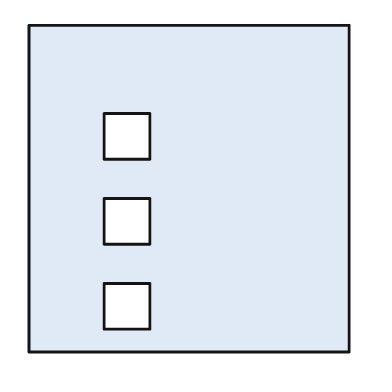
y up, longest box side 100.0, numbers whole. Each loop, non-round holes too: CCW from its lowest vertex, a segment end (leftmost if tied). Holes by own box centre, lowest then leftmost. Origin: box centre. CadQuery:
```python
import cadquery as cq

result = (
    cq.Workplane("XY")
    .moveTo(-49.0, -50.0)
    .lineTo(49.0, -50.0)
    .lineTo(49.0, 50.0)
    .lineTo(-49.0, 50.0)
    .close()
    .moveTo(-26.0, -43.0)
    .lineTo(-12.0, -43.0)
    .lineTo(-12.0, -29.0)
    .lineTo(-26.0, -29.0)
    .close()
    .moveTo(-26.0, -17.0)
    .lineTo(-12.0, -17.0)
    .lineTo(-12.0, -3.0)
    .lineTo(-26.0, -3.0)
    .close()
    .moveTo(-26.0, 9.0)
    .lineTo(-12.0, 9.0)
    .lineTo(-12.0, 23.0)
    .lineTo(-26.0, 23.0)
    .close()
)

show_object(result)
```